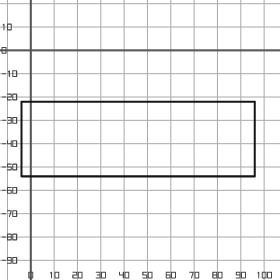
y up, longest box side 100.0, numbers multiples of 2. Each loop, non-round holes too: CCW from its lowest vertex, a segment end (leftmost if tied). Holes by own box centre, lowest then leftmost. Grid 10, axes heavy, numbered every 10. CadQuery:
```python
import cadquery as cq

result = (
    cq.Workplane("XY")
    .moveTo(-4.0, -54.0)
    .lineTo(96.0, -54.0)
    .lineTo(96.0, -22.0)
    .lineTo(-4.0, -22.0)
    .close()
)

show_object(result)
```